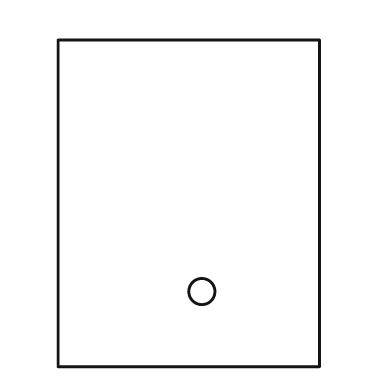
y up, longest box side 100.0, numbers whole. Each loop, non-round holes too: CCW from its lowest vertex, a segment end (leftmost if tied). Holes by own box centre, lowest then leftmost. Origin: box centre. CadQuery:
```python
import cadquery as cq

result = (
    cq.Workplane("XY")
    .moveTo(-40.0, -50.0)
    .lineTo(40.0, -50.0)
    .lineTo(40.0, 50.0)
    .lineTo(-40.0, 50.0)
    .close()
    .moveTo(4.0, -27.0)
    .circle(4.0)
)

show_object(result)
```